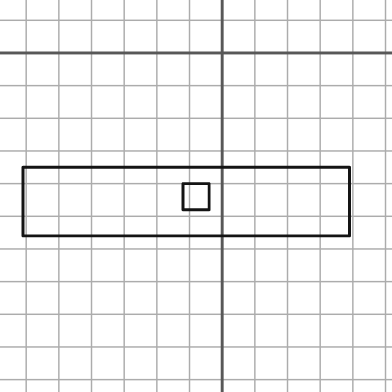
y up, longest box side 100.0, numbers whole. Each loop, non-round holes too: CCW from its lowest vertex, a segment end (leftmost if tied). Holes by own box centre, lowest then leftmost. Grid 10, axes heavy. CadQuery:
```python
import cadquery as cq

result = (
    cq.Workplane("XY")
    .moveTo(-61.0, -56.0)
    .lineTo(39.0, -56.0)
    .lineTo(39.0, -35.0)
    .lineTo(-61.0, -35.0)
    .close()
    .moveTo(-12.0, -48.0)
    .lineTo(-4.0, -48.0)
    .lineTo(-4.0, -40.0)
    .lineTo(-12.0, -40.0)
    .close()
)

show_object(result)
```